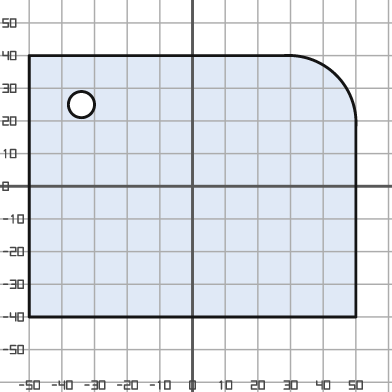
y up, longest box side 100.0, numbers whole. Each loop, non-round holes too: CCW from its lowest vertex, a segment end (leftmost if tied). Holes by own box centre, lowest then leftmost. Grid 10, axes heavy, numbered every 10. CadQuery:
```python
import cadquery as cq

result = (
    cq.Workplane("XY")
    .moveTo(-50.0, -40.0)
    .lineTo(50.0, -40.0)
    .lineTo(50.0, 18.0)
    .threePointArc((44.0, 34.0), (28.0, 40.0))
    .lineTo(-50.0, 40.0)
    .close()
    .moveTo(-34.0, 25.0)
    .circle(4.0)
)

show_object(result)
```